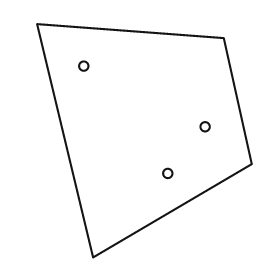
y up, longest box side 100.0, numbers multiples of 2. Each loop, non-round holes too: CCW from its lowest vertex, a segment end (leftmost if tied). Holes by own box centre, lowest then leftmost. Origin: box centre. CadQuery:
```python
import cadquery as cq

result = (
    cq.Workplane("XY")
    .moveTo(-22.0, -50.0)
    .lineTo(46.0, -10.0)
    .lineTo(34.0, 44.0)
    .lineTo(-46.0, 50.0)
    .close()
    .moveTo(10.0, -14.0)
    .circle(2.0)
    .moveTo(26.0, 6.0)
    .circle(2.0)
    .moveTo(-26.0, 32.0)
    .circle(2.0)
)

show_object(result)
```